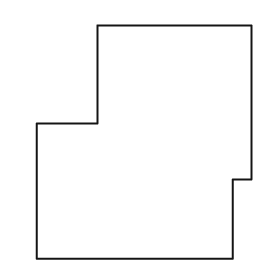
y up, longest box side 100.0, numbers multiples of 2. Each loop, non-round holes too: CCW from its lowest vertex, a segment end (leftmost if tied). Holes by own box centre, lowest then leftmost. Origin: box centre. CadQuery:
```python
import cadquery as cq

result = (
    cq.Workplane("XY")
    .moveTo(-46.0, -50.0)
    .lineTo(38.0, -50.0)
    .lineTo(38.0, -16.0)
    .lineTo(46.0, -16.0)
    .lineTo(46.0, 50.0)
    .lineTo(-20.0, 50.0)
    .lineTo(-20.0, 8.0)
    .lineTo(-46.0, 8.0)
    .close()
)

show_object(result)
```